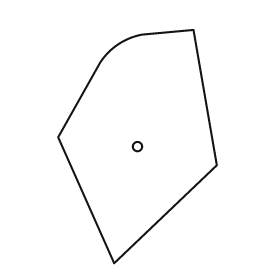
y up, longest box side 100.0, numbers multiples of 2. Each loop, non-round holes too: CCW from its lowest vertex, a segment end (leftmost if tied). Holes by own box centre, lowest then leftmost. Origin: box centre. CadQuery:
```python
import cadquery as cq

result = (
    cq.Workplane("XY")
    .moveTo(-10.0, -50.0)
    .lineTo(34.0, -8.0)
    .lineTo(24.0, 50.0)
    .lineTo(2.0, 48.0)
    .threePointArc((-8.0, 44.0), (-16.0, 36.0))
    .lineTo(-34.0, 4.0)
    .close()
    .moveTo(0.0, 0.0)
    .circle(2.0)
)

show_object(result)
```